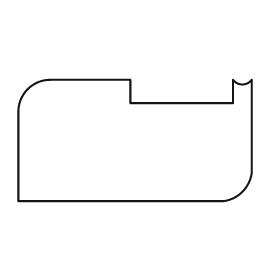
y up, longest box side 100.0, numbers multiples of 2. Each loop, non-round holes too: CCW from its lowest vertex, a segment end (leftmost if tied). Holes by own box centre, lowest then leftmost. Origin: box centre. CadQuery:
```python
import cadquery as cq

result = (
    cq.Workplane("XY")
    .moveTo(-50.0, -26.0)
    .lineTo(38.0, -26.0)
    .threePointArc((46.0, -22.0), (50.0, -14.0))
    .lineTo(50.0, 26.0)
    .threePointArc((46.0, 24.0), (42.0, 26.0))
    .lineTo(42.0, 16.0)
    .lineTo(-2.0, 16.0)
    .lineTo(-2.0, 26.0)
    .lineTo(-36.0, 26.0)
    .threePointArc((-46.0, 22.0), (-50.0, 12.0))
    .close()
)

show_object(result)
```